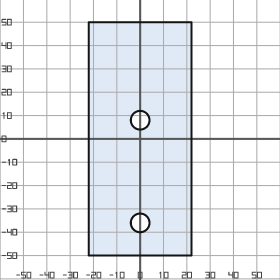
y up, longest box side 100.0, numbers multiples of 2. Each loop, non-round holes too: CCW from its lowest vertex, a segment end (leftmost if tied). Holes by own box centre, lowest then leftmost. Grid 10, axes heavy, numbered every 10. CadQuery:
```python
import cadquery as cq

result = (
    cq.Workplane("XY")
    .moveTo(-22.0, -50.0)
    .lineTo(22.0, -50.0)
    .lineTo(22.0, 50.0)
    .lineTo(-22.0, 50.0)
    .close()
    .moveTo(0.0, -36.0)
    .circle(4.0)
    .moveTo(0.0, 8.0)
    .circle(4.0)
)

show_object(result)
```